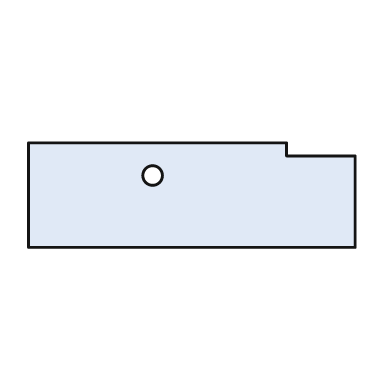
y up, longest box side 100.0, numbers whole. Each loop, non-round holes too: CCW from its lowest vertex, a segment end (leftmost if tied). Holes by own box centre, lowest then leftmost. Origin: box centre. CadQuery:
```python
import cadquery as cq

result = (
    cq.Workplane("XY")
    .moveTo(-50.0, -16.0)
    .lineTo(50.0, -16.0)
    .lineTo(50.0, 12.0)
    .lineTo(29.0, 12.0)
    .lineTo(29.0, 16.0)
    .lineTo(-50.0, 16.0)
    .close()
    .moveTo(-12.0, 6.0)
    .circle(3.0)
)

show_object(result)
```